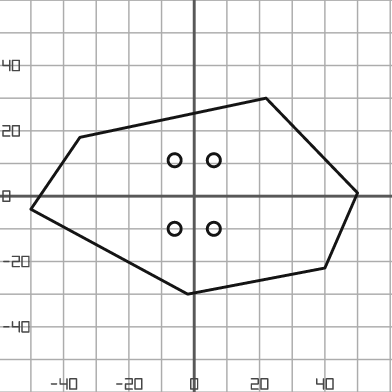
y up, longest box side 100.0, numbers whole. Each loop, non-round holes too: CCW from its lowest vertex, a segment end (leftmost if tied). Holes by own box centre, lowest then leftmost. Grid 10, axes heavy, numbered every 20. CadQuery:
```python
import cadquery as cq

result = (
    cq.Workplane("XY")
    .moveTo(-2.0, -30.0)
    .lineTo(40.0, -22.0)
    .lineTo(50.0, 1.0)
    .lineTo(22.0, 30.0)
    .lineTo(-35.0, 18.0)
    .lineTo(-50.0, -4.0)
    .close()
    .moveTo(-6.0, -10.0)
    .circle(2.0)
    .moveTo(6.0, -10.0)
    .circle(2.0)
    .moveTo(-6.0, 11.0)
    .circle(2.0)
    .moveTo(6.0, 11.0)
    .circle(2.0)
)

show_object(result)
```